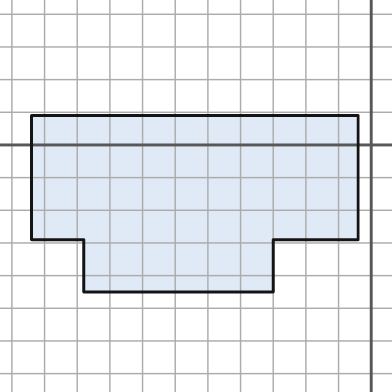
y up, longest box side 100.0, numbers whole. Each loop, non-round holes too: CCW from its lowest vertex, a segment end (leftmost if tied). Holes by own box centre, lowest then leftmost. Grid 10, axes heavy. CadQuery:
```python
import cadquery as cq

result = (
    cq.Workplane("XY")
    .moveTo(-88.0, -45.0)
    .lineTo(-30.0, -45.0)
    .lineTo(-30.0, -29.0)
    .lineTo(-4.0, -29.0)
    .lineTo(-4.0, 9.0)
    .lineTo(-104.0, 9.0)
    .lineTo(-104.0, -29.0)
    .lineTo(-88.0, -29.0)
    .close()
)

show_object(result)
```